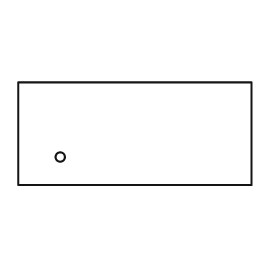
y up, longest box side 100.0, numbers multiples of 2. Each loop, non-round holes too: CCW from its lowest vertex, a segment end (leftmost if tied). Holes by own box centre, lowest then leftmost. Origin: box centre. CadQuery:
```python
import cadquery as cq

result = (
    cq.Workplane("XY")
    .moveTo(-50.0, -22.0)
    .lineTo(50.0, -22.0)
    .lineTo(50.0, 22.0)
    .lineTo(-50.0, 22.0)
    .close()
    .moveTo(-32.0, -10.0)
    .circle(2.0)
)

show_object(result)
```